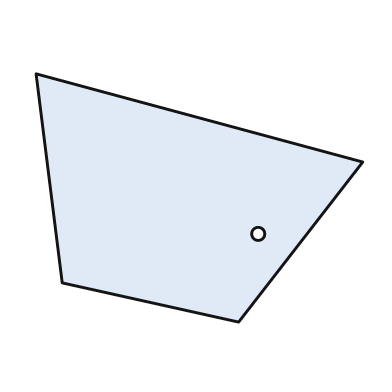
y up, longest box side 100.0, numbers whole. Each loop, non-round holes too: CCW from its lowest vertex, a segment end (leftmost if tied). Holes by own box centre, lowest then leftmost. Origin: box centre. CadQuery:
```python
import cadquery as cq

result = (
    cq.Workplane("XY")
    .moveTo(12.0, -38.0)
    .lineTo(50.0, 11.0)
    .lineTo(-50.0, 38.0)
    .lineTo(-42.0, -26.0)
    .close()
    .moveTo(18.0, -11.0)
    .circle(2.0)
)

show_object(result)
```